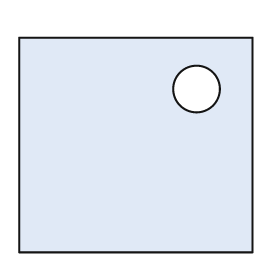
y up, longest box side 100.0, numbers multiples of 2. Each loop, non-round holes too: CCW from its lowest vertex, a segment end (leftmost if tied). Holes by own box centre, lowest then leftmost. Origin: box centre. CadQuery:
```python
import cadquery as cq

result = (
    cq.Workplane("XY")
    .moveTo(-50.0, -46.0)
    .lineTo(50.0, -46.0)
    .lineTo(50.0, 46.0)
    .lineTo(-50.0, 46.0)
    .close()
    .moveTo(26.0, 24.0)
    .circle(10.0)
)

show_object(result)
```